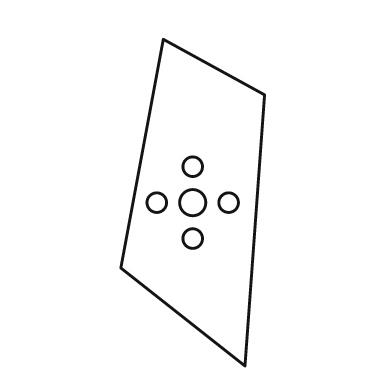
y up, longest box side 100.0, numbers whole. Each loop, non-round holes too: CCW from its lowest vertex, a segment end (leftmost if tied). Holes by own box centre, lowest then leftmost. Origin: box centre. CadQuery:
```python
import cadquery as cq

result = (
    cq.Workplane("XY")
    .moveTo(16.0, -50.0)
    .lineTo(22.0, 33.0)
    .lineTo(-9.0, 50.0)
    .lineTo(-22.0, -20.0)
    .close()
    .moveTo(0.0, -11.0)
    .circle(3.0)
    .moveTo(-11.0, 0.0)
    .circle(3.0)
    .moveTo(0.0, 0.0)
    .circle(4.0)
    .moveTo(11.0, 0.0)
    .circle(3.0)
    .moveTo(0.0, 11.0)
    .circle(3.0)
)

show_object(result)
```